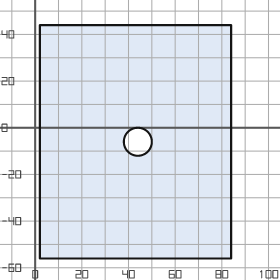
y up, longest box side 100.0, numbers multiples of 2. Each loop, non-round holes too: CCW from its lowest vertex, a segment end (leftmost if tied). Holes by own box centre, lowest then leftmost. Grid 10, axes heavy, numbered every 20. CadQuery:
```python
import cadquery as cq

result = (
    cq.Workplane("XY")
    .moveTo(2.0, -56.0)
    .lineTo(84.0, -56.0)
    .lineTo(84.0, 44.0)
    .lineTo(2.0, 44.0)
    .close()
    .moveTo(44.0, -6.0)
    .circle(6.0)
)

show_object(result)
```